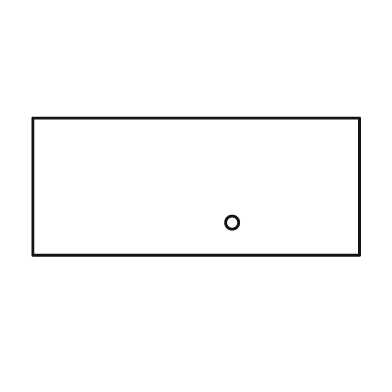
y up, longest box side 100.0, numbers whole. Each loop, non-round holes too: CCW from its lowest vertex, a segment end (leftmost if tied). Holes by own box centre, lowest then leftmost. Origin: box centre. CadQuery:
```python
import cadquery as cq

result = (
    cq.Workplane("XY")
    .moveTo(-50.0, -21.0)
    .lineTo(50.0, -21.0)
    .lineTo(50.0, 21.0)
    .lineTo(-50.0, 21.0)
    .close()
    .moveTo(11.0, -11.0)
    .circle(2.0)
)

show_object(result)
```